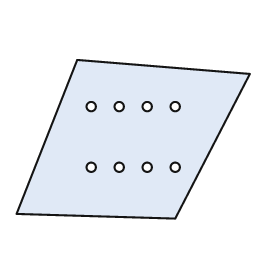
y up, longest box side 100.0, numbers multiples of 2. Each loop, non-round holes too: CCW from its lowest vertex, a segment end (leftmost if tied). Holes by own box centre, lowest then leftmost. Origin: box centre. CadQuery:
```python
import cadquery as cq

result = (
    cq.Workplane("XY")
    .moveTo(18.0, -34.0)
    .lineTo(50.0, 28.0)
    .lineTo(-24.0, 34.0)
    .lineTo(-50.0, -32.0)
    .close()
    .moveTo(-18.0, -12.0)
    .circle(2.0)
    .moveTo(-6.0, -12.0)
    .circle(2.0)
    .moveTo(6.0, -12.0)
    .circle(2.0)
    .moveTo(18.0, -12.0)
    .circle(2.0)
    .moveTo(-18.0, 14.0)
    .circle(2.0)
    .moveTo(-6.0, 14.0)
    .circle(2.0)
    .moveTo(6.0, 14.0)
    .circle(2.0)
    .moveTo(18.0, 14.0)
    .circle(2.0)
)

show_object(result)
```